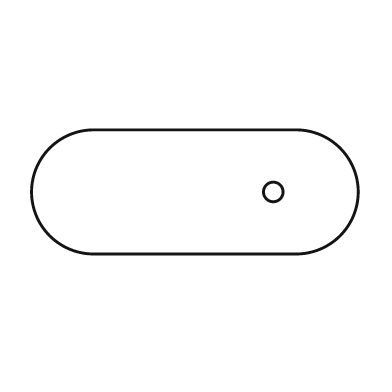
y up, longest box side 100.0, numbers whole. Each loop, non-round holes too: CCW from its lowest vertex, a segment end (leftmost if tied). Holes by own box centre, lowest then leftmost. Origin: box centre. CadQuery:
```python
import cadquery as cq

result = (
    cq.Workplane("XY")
    .moveTo(-31.0, -19.0)
    .lineTo(31.0, -19.0)
    .threePointArc((50.0, 0.0), (31.0, 19.0))
    .lineTo(-31.0, 19.0)
    .threePointArc((-50.0, 0.0), (-31.0, -19.0))
    .close()
    .moveTo(24.0, 0.0)
    .circle(3.0)
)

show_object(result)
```